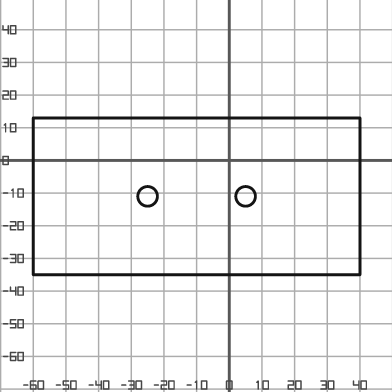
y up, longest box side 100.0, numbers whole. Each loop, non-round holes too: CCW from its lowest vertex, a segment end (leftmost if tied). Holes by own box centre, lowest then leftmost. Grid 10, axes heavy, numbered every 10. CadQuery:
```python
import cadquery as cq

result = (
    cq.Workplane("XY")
    .moveTo(-60.0, -35.0)
    .lineTo(40.0, -35.0)
    .lineTo(40.0, 13.0)
    .lineTo(-60.0, 13.0)
    .close()
    .moveTo(-25.0, -11.0)
    .circle(3.0)
    .moveTo(5.0, -11.0)
    .circle(3.0)
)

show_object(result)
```